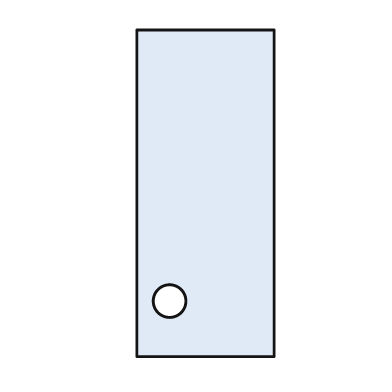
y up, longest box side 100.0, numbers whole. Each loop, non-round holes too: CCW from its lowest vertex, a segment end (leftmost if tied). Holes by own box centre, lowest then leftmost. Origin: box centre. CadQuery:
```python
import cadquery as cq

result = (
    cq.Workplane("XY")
    .moveTo(-21.0, -50.0)
    .lineTo(21.0, -50.0)
    .lineTo(21.0, 50.0)
    .lineTo(-21.0, 50.0)
    .close()
    .moveTo(-11.0, -33.0)
    .circle(5.0)
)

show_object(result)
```